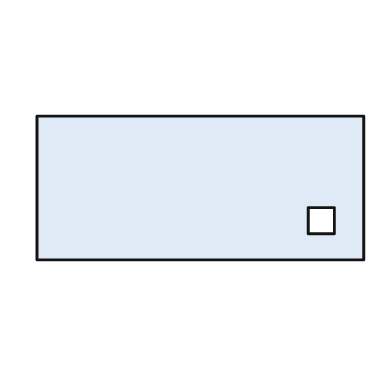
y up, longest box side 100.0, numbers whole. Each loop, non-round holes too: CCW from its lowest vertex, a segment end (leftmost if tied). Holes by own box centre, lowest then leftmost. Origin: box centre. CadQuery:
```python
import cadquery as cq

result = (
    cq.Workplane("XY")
    .moveTo(-50.0, -22.0)
    .lineTo(50.0, -22.0)
    .lineTo(50.0, 22.0)
    .lineTo(-50.0, 22.0)
    .close()
    .moveTo(33.0, -14.0)
    .lineTo(41.0, -14.0)
    .lineTo(41.0, -6.0)
    .lineTo(33.0, -6.0)
    .close()
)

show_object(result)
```